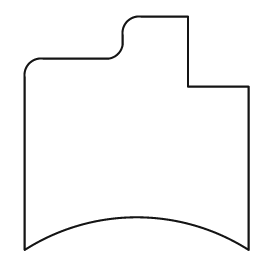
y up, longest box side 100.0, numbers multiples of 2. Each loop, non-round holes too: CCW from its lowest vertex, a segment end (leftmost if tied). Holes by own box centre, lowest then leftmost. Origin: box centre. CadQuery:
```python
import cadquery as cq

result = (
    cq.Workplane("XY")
    .moveTo(-48.0, -50.0)
    .threePointArc((0.0, -36.0), (48.0, -50.0))
    .lineTo(48.0, 20.0)
    .lineTo(22.0, 20.0)
    .lineTo(22.0, 50.0)
    .lineTo(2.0, 50.0)
    .threePointArc((-4.0, 48.0), (-6.0, 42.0))
    .lineTo(-6.0, 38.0)
    .threePointArc((-8.0, 34.0), (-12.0, 32.0))
    .lineTo(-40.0, 32.0)
    .threePointArc((-46.0, 30.0), (-48.0, 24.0))
    .close()
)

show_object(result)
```